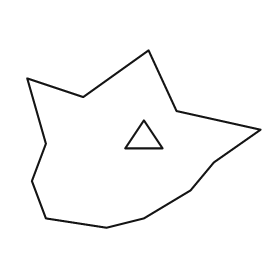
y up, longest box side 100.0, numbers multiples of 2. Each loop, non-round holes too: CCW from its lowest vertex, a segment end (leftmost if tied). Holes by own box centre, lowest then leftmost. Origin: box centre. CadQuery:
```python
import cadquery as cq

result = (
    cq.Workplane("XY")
    .moveTo(-16.0, -38.0)
    .lineTo(0.0, -34.0)
    .lineTo(20.0, -22.0)
    .lineTo(30.0, -10.0)
    .lineTo(50.0, 4.0)
    .lineTo(14.0, 12.0)
    .lineTo(2.0, 38.0)
    .lineTo(-26.0, 18.0)
    .lineTo(-50.0, 26.0)
    .lineTo(-42.0, -2.0)
    .lineTo(-48.0, -18.0)
    .lineTo(-42.0, -34.0)
    .close()
    .moveTo(-8.0, -4.0)
    .lineTo(8.0, -4.0)
    .lineTo(0.0, 8.0)
    .close()
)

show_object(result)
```